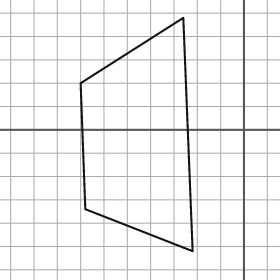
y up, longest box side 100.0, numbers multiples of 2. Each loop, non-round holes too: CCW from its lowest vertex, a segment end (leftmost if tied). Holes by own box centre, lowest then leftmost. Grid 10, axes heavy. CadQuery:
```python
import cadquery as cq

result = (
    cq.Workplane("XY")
    .moveTo(-22.0, -52.0)
    .lineTo(-26.0, 48.0)
    .lineTo(-70.0, 20.0)
    .lineTo(-68.0, -34.0)
    .close()
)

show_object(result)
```